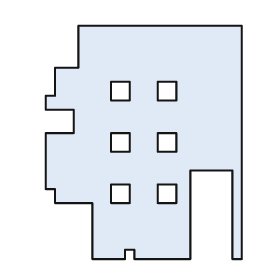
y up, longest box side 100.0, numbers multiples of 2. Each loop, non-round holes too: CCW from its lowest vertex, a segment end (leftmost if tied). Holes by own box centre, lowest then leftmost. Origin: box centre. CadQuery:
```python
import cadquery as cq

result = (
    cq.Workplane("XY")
    .moveTo(-22.0, -50.0)
    .lineTo(-8.0, -50.0)
    .lineTo(-8.0, -46.0)
    .lineTo(-4.0, -46.0)
    .lineTo(-4.0, -50.0)
    .lineTo(20.0, -50.0)
    .lineTo(20.0, -12.0)
    .lineTo(38.0, -12.0)
    .lineTo(38.0, -50.0)
    .lineTo(42.0, -50.0)
    .lineTo(42.0, 50.0)
    .lineTo(-28.0, 50.0)
    .lineTo(-28.0, 32.0)
    .lineTo(-38.0, 32.0)
    .lineTo(-38.0, 20.0)
    .lineTo(-42.0, 20.0)
    .lineTo(-42.0, 14.0)
    .lineTo(-30.0, 14.0)
    .lineTo(-30.0, 4.0)
    .lineTo(-42.0, 4.0)
    .lineTo(-42.0, -20.0)
    .lineTo(-38.0, -20.0)
    .lineTo(-38.0, -26.0)
    .lineTo(-22.0, -26.0)
    .close()
    .moveTo(-14.0, -26.0)
    .lineTo(-6.0, -26.0)
    .lineTo(-6.0, -18.0)
    .lineTo(-14.0, -18.0)
    .close()
    .moveTo(6.0, -26.0)
    .lineTo(14.0, -26.0)
    .lineTo(14.0, -18.0)
    .lineTo(6.0, -18.0)
    .close()
    .moveTo(-14.0, -4.0)
    .lineTo(-6.0, -4.0)
    .lineTo(-6.0, 4.0)
    .lineTo(-14.0, 4.0)
    .close()
    .moveTo(6.0, -4.0)
    .lineTo(14.0, -4.0)
    .lineTo(14.0, 4.0)
    .lineTo(6.0, 4.0)
    .close()
    .moveTo(-14.0, 18.0)
    .lineTo(-6.0, 18.0)
    .lineTo(-6.0, 26.0)
    .lineTo(-14.0, 26.0)
    .close()
    .moveTo(6.0, 18.0)
    .lineTo(14.0, 18.0)
    .lineTo(14.0, 26.0)
    .lineTo(6.0, 26.0)
    .close()
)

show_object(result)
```